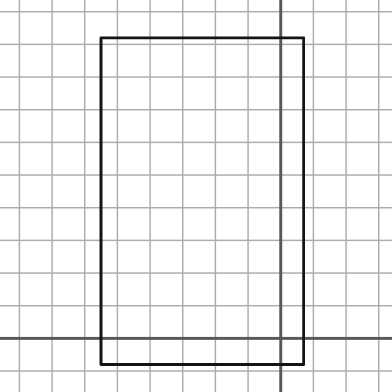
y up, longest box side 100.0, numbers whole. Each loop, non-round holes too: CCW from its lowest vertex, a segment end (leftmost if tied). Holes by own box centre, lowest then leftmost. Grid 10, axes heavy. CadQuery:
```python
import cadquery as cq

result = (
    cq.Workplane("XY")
    .moveTo(-55.0, -8.0)
    .lineTo(7.0, -8.0)
    .lineTo(7.0, 92.0)
    .lineTo(-55.0, 92.0)
    .close()
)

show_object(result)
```